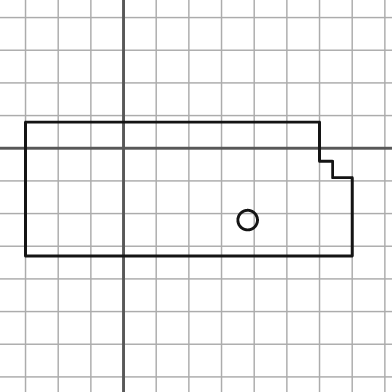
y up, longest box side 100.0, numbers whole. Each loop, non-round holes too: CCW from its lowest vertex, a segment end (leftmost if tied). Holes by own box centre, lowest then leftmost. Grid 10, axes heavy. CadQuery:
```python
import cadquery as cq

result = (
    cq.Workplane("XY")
    .moveTo(-30.0, -33.0)
    .lineTo(70.0, -33.0)
    .lineTo(70.0, -9.0)
    .lineTo(64.0, -9.0)
    .lineTo(64.0, -4.0)
    .lineTo(60.0, -4.0)
    .lineTo(60.0, 8.0)
    .lineTo(-30.0, 8.0)
    .close()
    .moveTo(38.0, -22.0)
    .circle(3.0)
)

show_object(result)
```